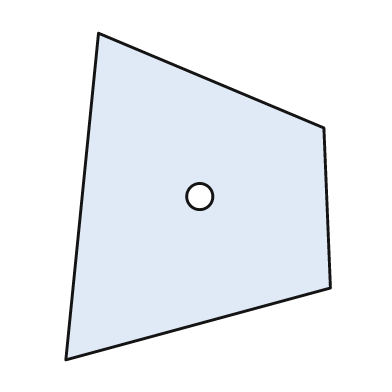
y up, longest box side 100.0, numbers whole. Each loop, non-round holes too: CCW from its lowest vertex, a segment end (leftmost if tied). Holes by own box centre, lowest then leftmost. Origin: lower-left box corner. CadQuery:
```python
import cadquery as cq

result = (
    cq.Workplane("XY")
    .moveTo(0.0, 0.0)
    .lineTo(81.0, 22.0)
    .lineTo(79.0, 71.0)
    .lineTo(10.0, 100.0)
    .close()
    .moveTo(41.0, 50.0)
    .circle(4.0)
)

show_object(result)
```